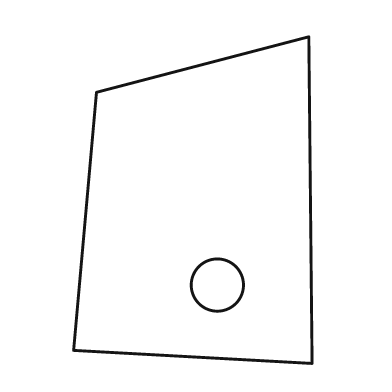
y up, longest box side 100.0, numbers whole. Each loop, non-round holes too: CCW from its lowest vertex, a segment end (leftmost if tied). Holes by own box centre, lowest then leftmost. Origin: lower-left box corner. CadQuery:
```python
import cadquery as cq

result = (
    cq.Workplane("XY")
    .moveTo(73.0, 0.0)
    .lineTo(72.0, 100.0)
    .lineTo(7.0, 83.0)
    .lineTo(0.0, 4.0)
    .close()
    .moveTo(44.0, 24.0)
    .circle(8.0)
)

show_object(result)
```